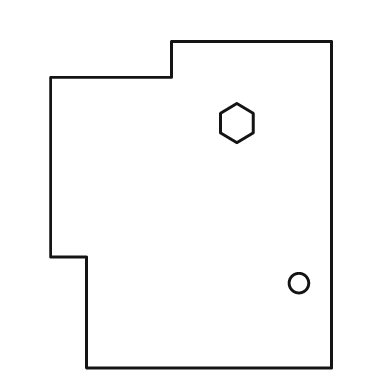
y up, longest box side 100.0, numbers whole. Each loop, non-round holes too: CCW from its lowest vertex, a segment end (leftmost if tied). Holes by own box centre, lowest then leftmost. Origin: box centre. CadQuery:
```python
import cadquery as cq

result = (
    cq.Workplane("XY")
    .moveTo(-32.0, -50.0)
    .lineTo(43.0, -50.0)
    .lineTo(43.0, 50.0)
    .lineTo(-6.0, 50.0)
    .lineTo(-6.0, 39.0)
    .lineTo(-43.0, 39.0)
    .lineTo(-43.0, -16.0)
    .lineTo(-32.0, -16.0)
    .close()
    .moveTo(33.0, -24.0)
    .circle(3.0)
    .moveTo(14.0, 19.0)
    .lineTo(19.0, 22.0)
    .lineTo(19.0, 28.0)
    .lineTo(14.0, 31.0)
    .lineTo(9.0, 28.0)
    .lineTo(9.0, 22.0)
    .close()
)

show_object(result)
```